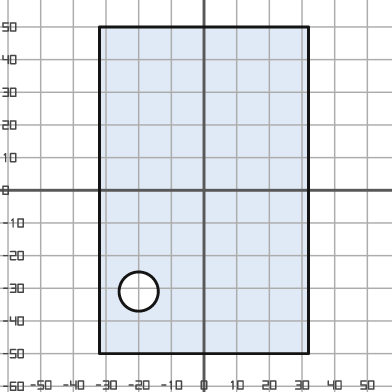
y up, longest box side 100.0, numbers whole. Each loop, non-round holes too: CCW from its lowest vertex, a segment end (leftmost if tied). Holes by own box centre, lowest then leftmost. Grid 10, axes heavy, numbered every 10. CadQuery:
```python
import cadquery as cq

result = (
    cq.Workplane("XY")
    .moveTo(-32.0, -50.0)
    .lineTo(32.0, -50.0)
    .lineTo(32.0, 50.0)
    .lineTo(-32.0, 50.0)
    .close()
    .moveTo(-20.0, -31.0)
    .circle(6.0)
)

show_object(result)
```